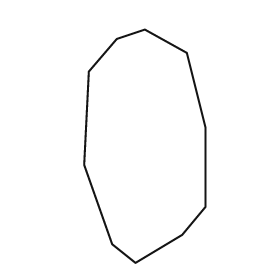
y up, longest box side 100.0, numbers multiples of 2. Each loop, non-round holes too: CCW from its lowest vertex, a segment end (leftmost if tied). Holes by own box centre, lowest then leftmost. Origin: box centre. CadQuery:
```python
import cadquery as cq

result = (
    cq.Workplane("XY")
    .moveTo(-4.0, -50.0)
    .lineTo(16.0, -38.0)
    .lineTo(26.0, -26.0)
    .lineTo(26.0, 8.0)
    .lineTo(18.0, 40.0)
    .lineTo(0.0, 50.0)
    .lineTo(-12.0, 46.0)
    .lineTo(-24.0, 32.0)
    .lineTo(-26.0, -8.0)
    .lineTo(-14.0, -42.0)
    .close()
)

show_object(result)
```